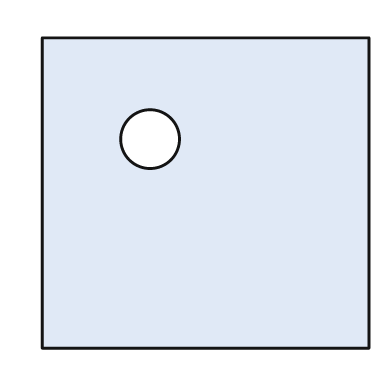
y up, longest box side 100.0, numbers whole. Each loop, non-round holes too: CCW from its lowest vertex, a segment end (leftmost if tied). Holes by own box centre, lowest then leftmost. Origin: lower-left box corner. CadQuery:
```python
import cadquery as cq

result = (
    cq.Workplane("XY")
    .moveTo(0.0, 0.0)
    .lineTo(100.0, 0.0)
    .lineTo(100.0, 95.0)
    .lineTo(0.0, 95.0)
    .close()
    .moveTo(33.0, 64.0)
    .circle(9.0)
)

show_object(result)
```